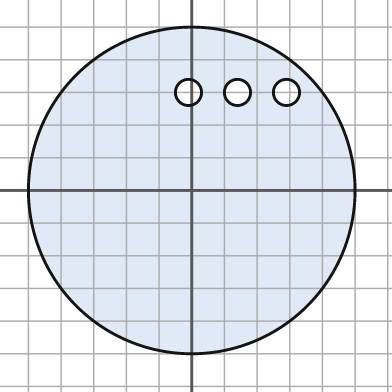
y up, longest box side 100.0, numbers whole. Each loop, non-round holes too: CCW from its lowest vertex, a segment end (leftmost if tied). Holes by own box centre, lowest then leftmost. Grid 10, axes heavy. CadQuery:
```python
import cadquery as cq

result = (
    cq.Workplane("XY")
    .moveTo(0.0, 0.0)
    .circle(50.0)
    .moveTo(-1.0, 30.0)
    .circle(4.0)
    .moveTo(14.0, 30.0)
    .circle(4.0)
    .moveTo(29.0, 30.0)
    .circle(4.0)
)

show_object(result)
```